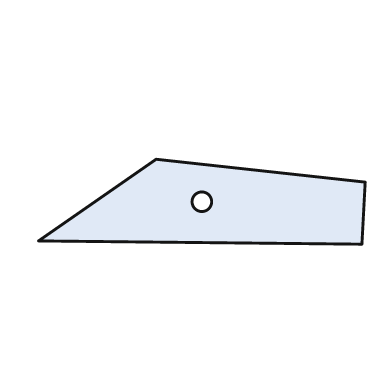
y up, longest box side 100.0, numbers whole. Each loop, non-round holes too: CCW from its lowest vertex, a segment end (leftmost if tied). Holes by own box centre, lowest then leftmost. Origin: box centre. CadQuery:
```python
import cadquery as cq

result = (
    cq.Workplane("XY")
    .moveTo(49.0, -13.0)
    .lineTo(50.0, 6.0)
    .lineTo(-14.0, 13.0)
    .lineTo(-50.0, -12.0)
    .close()
    .moveTo(0.0, 0.0)
    .circle(3.0)
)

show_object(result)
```